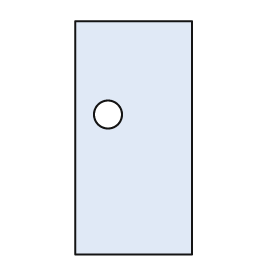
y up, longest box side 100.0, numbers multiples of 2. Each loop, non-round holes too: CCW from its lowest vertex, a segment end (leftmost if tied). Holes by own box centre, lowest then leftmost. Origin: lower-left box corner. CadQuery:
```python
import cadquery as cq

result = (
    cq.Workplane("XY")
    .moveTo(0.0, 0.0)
    .lineTo(50.0, 0.0)
    .lineTo(50.0, 100.0)
    .lineTo(0.0, 100.0)
    .close()
    .moveTo(14.0, 60.0)
    .circle(6.0)
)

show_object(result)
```